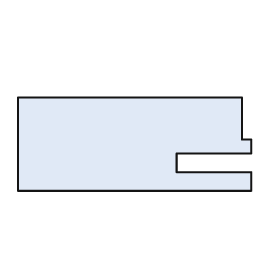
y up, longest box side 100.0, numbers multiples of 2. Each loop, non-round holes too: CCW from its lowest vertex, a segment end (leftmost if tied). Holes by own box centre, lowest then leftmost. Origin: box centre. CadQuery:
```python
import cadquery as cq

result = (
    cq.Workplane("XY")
    .moveTo(-50.0, -20.0)
    .lineTo(50.0, -20.0)
    .lineTo(50.0, -12.0)
    .lineTo(18.0, -12.0)
    .lineTo(18.0, -4.0)
    .lineTo(50.0, -4.0)
    .lineTo(50.0, 2.0)
    .lineTo(46.0, 2.0)
    .lineTo(46.0, 20.0)
    .lineTo(-50.0, 20.0)
    .close()
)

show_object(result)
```